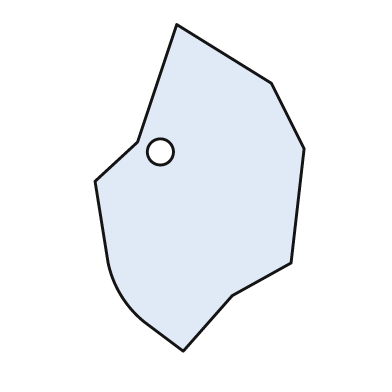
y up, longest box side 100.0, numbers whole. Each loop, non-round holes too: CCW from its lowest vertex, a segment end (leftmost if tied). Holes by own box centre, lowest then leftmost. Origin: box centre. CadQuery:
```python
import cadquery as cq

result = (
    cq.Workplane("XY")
    .moveTo(-5.0, -50.0)
    .lineTo(10.0, -33.0)
    .lineTo(28.0, -23.0)
    .lineTo(32.0, 12.0)
    .lineTo(22.0, 32.0)
    .lineTo(-7.0, 50.0)
    .lineTo(-19.0, 14.0)
    .lineTo(-32.0, 2.0)
    .lineTo(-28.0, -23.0)
    .threePointArc((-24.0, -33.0), (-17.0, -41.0))
    .close()
    .moveTo(-12.0, 11.0)
    .circle(4.0)
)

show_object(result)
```